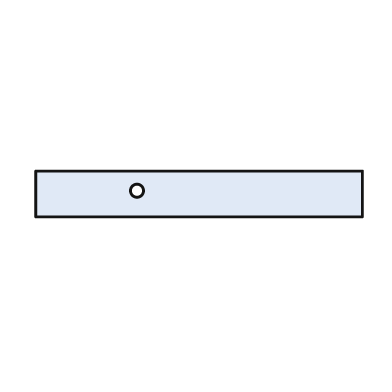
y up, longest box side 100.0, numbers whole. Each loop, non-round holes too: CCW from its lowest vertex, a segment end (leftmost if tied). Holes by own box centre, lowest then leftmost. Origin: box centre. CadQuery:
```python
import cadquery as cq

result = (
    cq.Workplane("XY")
    .moveTo(-50.0, -7.0)
    .lineTo(50.0, -7.0)
    .lineTo(50.0, 7.0)
    .lineTo(-50.0, 7.0)
    .close()
    .moveTo(-19.0, 1.0)
    .circle(2.0)
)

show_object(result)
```